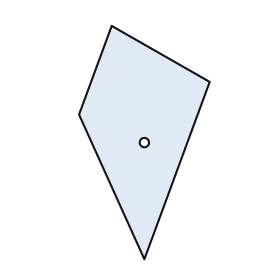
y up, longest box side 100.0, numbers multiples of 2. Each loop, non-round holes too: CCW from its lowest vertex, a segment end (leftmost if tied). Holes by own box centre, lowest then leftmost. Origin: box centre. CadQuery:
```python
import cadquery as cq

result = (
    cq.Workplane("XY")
    .moveTo(0.0, -50.0)
    .lineTo(28.0, 26.0)
    .lineTo(-14.0, 50.0)
    .lineTo(-28.0, 12.0)
    .close()
    .moveTo(0.0, 0.0)
    .circle(2.0)
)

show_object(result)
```